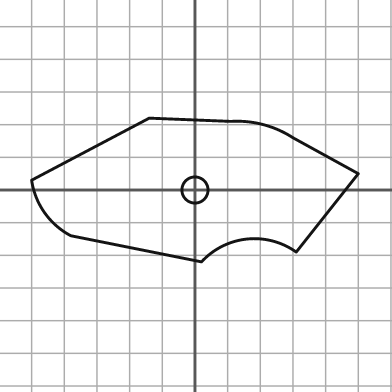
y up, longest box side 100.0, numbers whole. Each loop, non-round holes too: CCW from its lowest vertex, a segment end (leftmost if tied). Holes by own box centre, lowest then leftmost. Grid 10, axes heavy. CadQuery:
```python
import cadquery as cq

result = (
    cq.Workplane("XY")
    .moveTo(2.0, -22.0)
    .threePointArc((16.0, -15.0), (31.0, -19.0))
    .lineTo(50.0, 5.0)
    .lineTo(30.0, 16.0)
    .threePointArc((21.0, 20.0), (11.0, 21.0))
    .lineTo(-14.0, 22.0)
    .lineTo(-50.0, 3.0)
    .threePointArc((-46.0, -7.0), (-38.0, -14.0))
    .close()
    .moveTo(0.0, 0.0)
    .circle(4.0)
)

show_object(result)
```